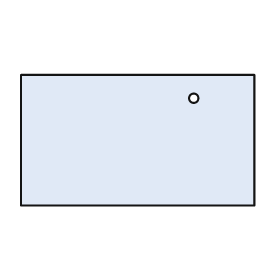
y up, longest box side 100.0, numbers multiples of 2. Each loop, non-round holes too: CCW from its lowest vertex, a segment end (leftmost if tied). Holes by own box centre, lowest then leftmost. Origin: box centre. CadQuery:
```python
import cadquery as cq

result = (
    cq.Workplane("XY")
    .moveTo(-50.0, -28.0)
    .lineTo(50.0, -28.0)
    .lineTo(50.0, 28.0)
    .lineTo(-50.0, 28.0)
    .close()
    .moveTo(24.0, 18.0)
    .circle(2.0)
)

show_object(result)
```